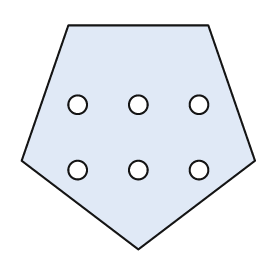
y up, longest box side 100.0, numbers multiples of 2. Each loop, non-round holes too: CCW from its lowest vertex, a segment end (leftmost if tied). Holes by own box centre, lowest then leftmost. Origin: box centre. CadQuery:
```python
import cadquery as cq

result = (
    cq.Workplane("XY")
    .moveTo(0.0, -48.0)
    .lineTo(50.0, -10.0)
    .lineTo(30.0, 48.0)
    .lineTo(-30.0, 48.0)
    .lineTo(-50.0, -10.0)
    .close()
    .moveTo(-26.0, -14.0)
    .circle(4.0)
    .moveTo(0.0, -14.0)
    .circle(4.0)
    .moveTo(26.0, -14.0)
    .circle(4.0)
    .moveTo(-26.0, 14.0)
    .circle(4.0)
    .moveTo(0.0, 14.0)
    .circle(4.0)
    .moveTo(26.0, 14.0)
    .circle(4.0)
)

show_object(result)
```